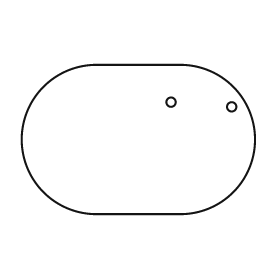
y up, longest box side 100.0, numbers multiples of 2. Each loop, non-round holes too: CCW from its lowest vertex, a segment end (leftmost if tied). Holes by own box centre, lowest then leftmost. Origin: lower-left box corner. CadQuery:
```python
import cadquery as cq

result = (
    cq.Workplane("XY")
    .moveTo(32.0, 0.0)
    .lineTo(68.0, 0.0)
    .threePointArc((100.0, 32.0), (68.0, 64.0))
    .lineTo(32.0, 64.0)
    .threePointArc((0.0, 32.0), (32.0, 0.0))
    .close()
    .moveTo(90.0, 46.0)
    .circle(2.0)
    .moveTo(64.0, 48.0)
    .circle(2.0)
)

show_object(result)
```